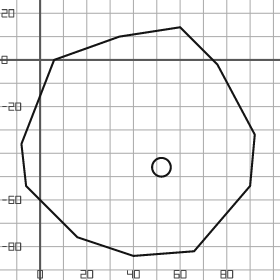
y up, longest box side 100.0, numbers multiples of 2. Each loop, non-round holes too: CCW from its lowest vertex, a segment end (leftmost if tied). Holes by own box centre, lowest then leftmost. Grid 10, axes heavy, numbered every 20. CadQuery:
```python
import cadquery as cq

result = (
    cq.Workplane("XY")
    .moveTo(40.0, -84.0)
    .lineTo(66.0, -82.0)
    .lineTo(90.0, -54.0)
    .lineTo(92.0, -32.0)
    .lineTo(76.0, -2.0)
    .lineTo(60.0, 14.0)
    .lineTo(34.0, 10.0)
    .lineTo(6.0, 0.0)
    .lineTo(-8.0, -36.0)
    .lineTo(-6.0, -54.0)
    .lineTo(16.0, -76.0)
    .close()
    .moveTo(52.0, -46.0)
    .circle(4.0)
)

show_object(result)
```